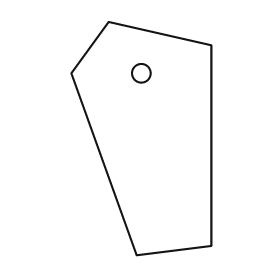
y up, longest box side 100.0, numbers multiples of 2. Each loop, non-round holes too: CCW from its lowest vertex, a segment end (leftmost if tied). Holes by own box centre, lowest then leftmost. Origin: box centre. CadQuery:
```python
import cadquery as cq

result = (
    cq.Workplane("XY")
    .moveTo(-2.0, -50.0)
    .lineTo(30.0, -46.0)
    .lineTo(30.0, 40.0)
    .lineTo(-14.0, 50.0)
    .lineTo(-30.0, 28.0)
    .close()
    .moveTo(0.0, 28.0)
    .circle(4.0)
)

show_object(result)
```